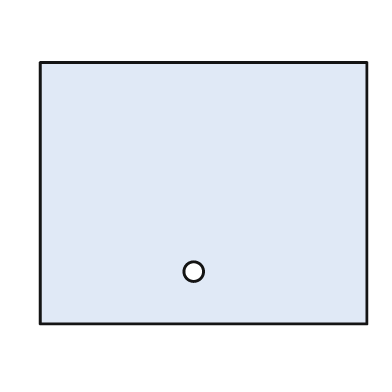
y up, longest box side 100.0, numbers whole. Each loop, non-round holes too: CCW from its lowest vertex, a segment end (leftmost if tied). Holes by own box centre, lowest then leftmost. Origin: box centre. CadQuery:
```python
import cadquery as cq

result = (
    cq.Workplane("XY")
    .moveTo(-50.0, -40.0)
    .lineTo(50.0, -40.0)
    .lineTo(50.0, 40.0)
    .lineTo(-50.0, 40.0)
    .close()
    .moveTo(-3.0, -24.0)
    .circle(3.0)
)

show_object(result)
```